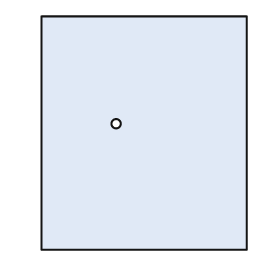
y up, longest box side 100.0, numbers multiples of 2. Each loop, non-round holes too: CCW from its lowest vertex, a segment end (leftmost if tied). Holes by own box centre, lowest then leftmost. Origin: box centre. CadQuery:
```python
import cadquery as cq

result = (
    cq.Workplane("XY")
    .moveTo(-44.0, -50.0)
    .lineTo(44.0, -50.0)
    .lineTo(44.0, 50.0)
    .lineTo(-44.0, 50.0)
    .close()
    .moveTo(-12.0, 4.0)
    .circle(2.0)
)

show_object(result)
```